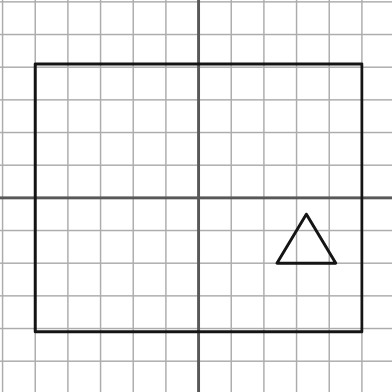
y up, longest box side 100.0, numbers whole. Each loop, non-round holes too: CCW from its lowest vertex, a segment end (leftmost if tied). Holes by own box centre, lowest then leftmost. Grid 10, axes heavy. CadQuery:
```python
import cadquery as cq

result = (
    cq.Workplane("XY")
    .moveTo(-50.0, -41.0)
    .lineTo(50.0, -41.0)
    .lineTo(50.0, 41.0)
    .lineTo(-50.0, 41.0)
    .close()
    .moveTo(24.0, -20.0)
    .lineTo(42.0, -20.0)
    .lineTo(33.0, -5.0)
    .close()
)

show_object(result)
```